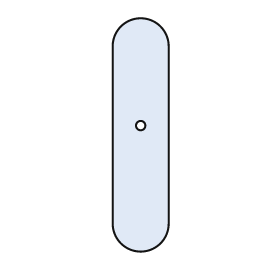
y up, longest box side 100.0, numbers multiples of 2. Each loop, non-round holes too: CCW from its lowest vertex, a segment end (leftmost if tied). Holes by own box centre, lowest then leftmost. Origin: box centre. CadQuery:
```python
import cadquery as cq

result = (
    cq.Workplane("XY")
    .moveTo(-12.0, -38.0)
    .threePointArc((0.0, -50.0), (12.0, -38.0))
    .lineTo(12.0, 38.0)
    .threePointArc((0.0, 50.0), (-12.0, 38.0))
    .close()
    .moveTo(0.0, 4.0)
    .circle(2.0)
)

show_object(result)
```